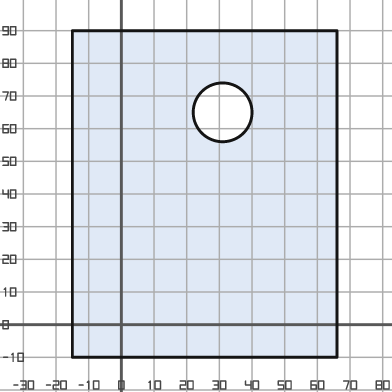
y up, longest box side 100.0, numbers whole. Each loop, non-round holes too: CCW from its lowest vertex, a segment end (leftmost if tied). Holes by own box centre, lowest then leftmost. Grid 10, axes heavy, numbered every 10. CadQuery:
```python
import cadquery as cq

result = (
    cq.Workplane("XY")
    .moveTo(-15.0, -10.0)
    .lineTo(66.0, -10.0)
    .lineTo(66.0, 90.0)
    .lineTo(-15.0, 90.0)
    .close()
    .moveTo(31.0, 65.0)
    .circle(9.0)
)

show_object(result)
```